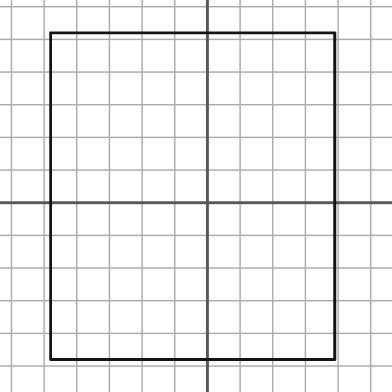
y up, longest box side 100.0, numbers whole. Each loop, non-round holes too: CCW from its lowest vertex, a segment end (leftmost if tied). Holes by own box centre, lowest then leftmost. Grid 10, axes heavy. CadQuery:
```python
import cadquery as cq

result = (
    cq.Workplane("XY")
    .moveTo(-48.0, -48.0)
    .lineTo(39.0, -48.0)
    .lineTo(39.0, 52.0)
    .lineTo(-48.0, 52.0)
    .close()
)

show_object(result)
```